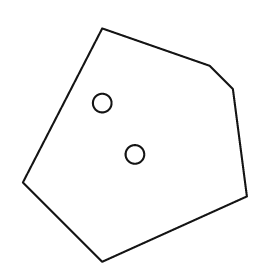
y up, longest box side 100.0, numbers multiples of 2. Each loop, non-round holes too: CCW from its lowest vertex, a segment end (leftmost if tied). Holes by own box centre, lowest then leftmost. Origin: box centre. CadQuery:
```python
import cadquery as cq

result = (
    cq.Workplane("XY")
    .moveTo(-14.0, -50.0)
    .lineTo(48.0, -22.0)
    .lineTo(42.0, 24.0)
    .lineTo(32.0, 34.0)
    .lineTo(-14.0, 50.0)
    .lineTo(-48.0, -16.0)
    .close()
    .moveTo(0.0, -4.0)
    .circle(4.0)
    .moveTo(-14.0, 18.0)
    .circle(4.0)
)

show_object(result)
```